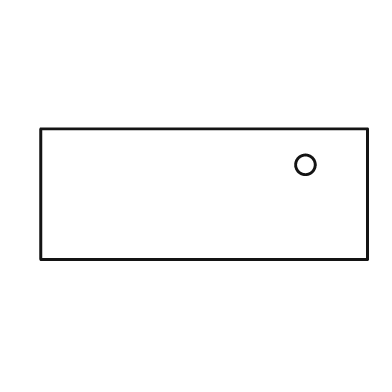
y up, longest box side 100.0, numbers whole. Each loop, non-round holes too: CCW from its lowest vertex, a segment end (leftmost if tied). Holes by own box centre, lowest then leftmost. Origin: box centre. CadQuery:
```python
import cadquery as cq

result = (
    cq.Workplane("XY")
    .moveTo(-50.0, -20.0)
    .lineTo(50.0, -20.0)
    .lineTo(50.0, 20.0)
    .lineTo(-50.0, 20.0)
    .close()
    .moveTo(31.0, 9.0)
    .circle(3.0)
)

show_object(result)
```